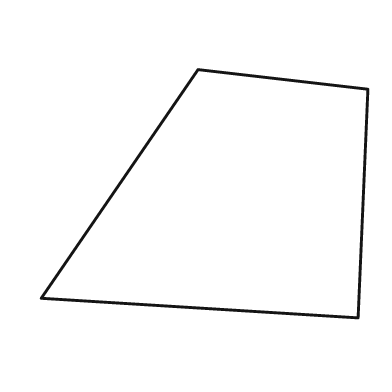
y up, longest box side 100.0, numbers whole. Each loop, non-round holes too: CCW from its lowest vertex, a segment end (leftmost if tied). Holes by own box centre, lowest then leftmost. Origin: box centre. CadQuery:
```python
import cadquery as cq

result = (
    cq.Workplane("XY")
    .moveTo(47.0, -38.0)
    .lineTo(50.0, 32.0)
    .lineTo(-2.0, 38.0)
    .lineTo(-50.0, -32.0)
    .close()
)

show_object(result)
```